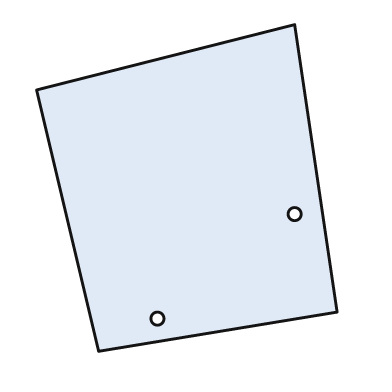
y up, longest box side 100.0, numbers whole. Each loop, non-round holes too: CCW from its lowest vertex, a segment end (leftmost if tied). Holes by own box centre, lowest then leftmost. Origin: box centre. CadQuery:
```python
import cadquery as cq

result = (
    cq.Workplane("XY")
    .moveTo(-27.0, -50.0)
    .lineTo(46.0, -38.0)
    .lineTo(33.0, 50.0)
    .lineTo(-46.0, 30.0)
    .close()
    .moveTo(-9.0, -40.0)
    .circle(2.0)
    .moveTo(33.0, -8.0)
    .circle(2.0)
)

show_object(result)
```